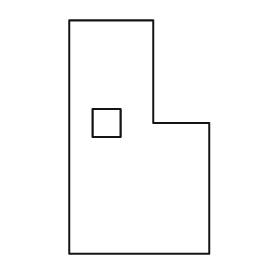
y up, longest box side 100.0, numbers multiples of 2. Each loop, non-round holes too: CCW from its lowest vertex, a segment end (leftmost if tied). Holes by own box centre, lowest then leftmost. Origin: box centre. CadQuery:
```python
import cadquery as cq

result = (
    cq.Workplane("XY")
    .moveTo(-30.0, -50.0)
    .lineTo(30.0, -50.0)
    .lineTo(30.0, 6.0)
    .lineTo(6.0, 6.0)
    .lineTo(6.0, 50.0)
    .lineTo(-30.0, 50.0)
    .close()
    .moveTo(-20.0, 0.0)
    .lineTo(-8.0, 0.0)
    .lineTo(-8.0, 12.0)
    .lineTo(-20.0, 12.0)
    .close()
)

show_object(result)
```